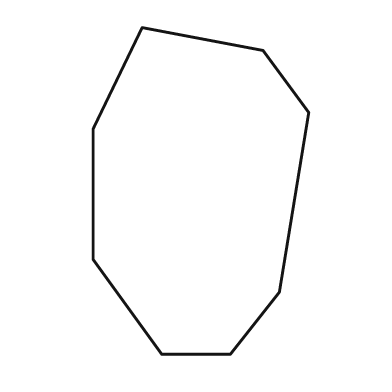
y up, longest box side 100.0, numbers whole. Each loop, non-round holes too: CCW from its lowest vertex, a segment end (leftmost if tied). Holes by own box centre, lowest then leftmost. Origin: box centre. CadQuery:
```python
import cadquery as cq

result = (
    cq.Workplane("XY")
    .moveTo(-12.0, -50.0)
    .lineTo(9.0, -50.0)
    .lineTo(24.0, -31.0)
    .lineTo(33.0, 24.0)
    .lineTo(19.0, 43.0)
    .lineTo(-18.0, 50.0)
    .lineTo(-33.0, 19.0)
    .lineTo(-33.0, -21.0)
    .close()
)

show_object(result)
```